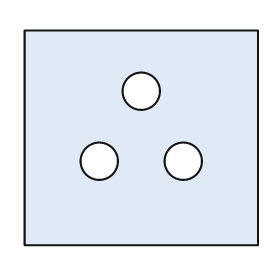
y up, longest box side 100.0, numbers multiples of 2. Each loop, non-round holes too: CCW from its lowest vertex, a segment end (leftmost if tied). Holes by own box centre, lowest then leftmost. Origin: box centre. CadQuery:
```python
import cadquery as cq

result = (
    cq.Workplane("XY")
    .moveTo(-50.0, -46.0)
    .lineTo(50.0, -46.0)
    .lineTo(50.0, 46.0)
    .lineTo(-50.0, 46.0)
    .close()
    .moveTo(-18.0, -10.0)
    .circle(8.0)
    .moveTo(18.0, -10.0)
    .circle(8.0)
    .moveTo(0.0, 20.0)
    .circle(8.0)
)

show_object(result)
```